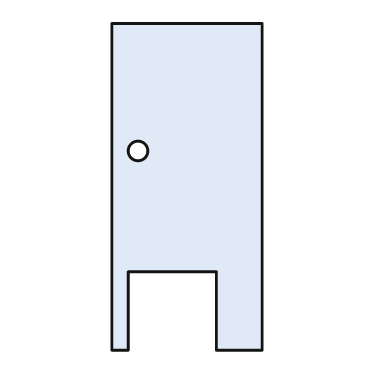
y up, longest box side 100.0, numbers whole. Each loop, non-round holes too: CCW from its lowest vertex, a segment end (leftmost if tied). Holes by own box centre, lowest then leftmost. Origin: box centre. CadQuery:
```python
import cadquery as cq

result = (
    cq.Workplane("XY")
    .moveTo(-23.0, -50.0)
    .lineTo(-18.0, -50.0)
    .lineTo(-18.0, -26.0)
    .lineTo(9.0, -26.0)
    .lineTo(9.0, -50.0)
    .lineTo(23.0, -50.0)
    .lineTo(23.0, 50.0)
    .lineTo(-23.0, 50.0)
    .close()
    .moveTo(-15.0, 11.0)
    .circle(3.0)
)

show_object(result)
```